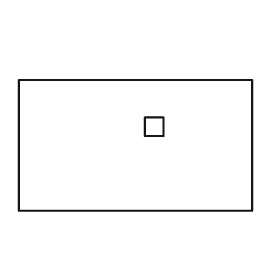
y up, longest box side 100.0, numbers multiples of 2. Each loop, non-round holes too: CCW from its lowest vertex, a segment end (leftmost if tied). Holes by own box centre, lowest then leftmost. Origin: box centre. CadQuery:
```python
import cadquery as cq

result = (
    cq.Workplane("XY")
    .moveTo(-50.0, -28.0)
    .lineTo(50.0, -28.0)
    .lineTo(50.0, 28.0)
    .lineTo(-50.0, 28.0)
    .close()
    .moveTo(4.0, 4.0)
    .lineTo(12.0, 4.0)
    .lineTo(12.0, 12.0)
    .lineTo(4.0, 12.0)
    .close()
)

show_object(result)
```